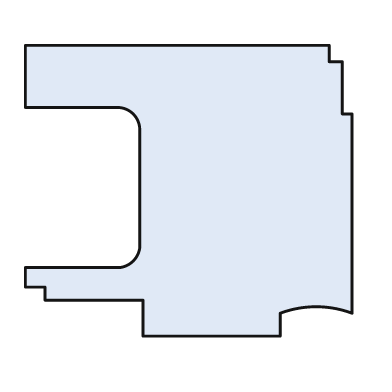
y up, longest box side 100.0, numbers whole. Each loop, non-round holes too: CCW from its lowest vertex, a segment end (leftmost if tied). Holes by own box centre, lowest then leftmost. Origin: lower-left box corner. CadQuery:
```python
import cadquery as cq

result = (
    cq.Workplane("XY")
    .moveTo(36.0, 0.0)
    .lineTo(78.0, 0.0)
    .lineTo(78.0, 7.0)
    .threePointArc((89.0, 9.0), (100.0, 7.0))
    .lineTo(100.0, 68.0)
    .lineTo(97.0, 68.0)
    .lineTo(97.0, 84.0)
    .lineTo(93.0, 84.0)
    .lineTo(93.0, 89.0)
    .lineTo(0.0, 89.0)
    .lineTo(0.0, 70.0)
    .lineTo(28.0, 70.0)
    .threePointArc((33.0, 68.0), (35.0, 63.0))
    .lineTo(35.0, 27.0)
    .threePointArc((33.0, 23.0), (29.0, 21.0))
    .lineTo(0.0, 21.0)
    .lineTo(0.0, 15.0)
    .lineTo(6.0, 15.0)
    .lineTo(6.0, 11.0)
    .lineTo(36.0, 11.0)
    .close()
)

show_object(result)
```